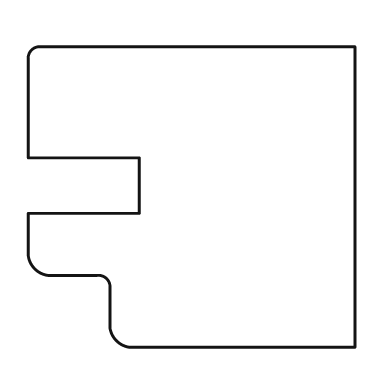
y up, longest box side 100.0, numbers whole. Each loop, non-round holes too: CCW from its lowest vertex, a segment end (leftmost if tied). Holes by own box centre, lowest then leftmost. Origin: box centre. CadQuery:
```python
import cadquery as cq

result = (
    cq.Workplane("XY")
    .moveTo(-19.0, -46.0)
    .lineTo(50.0, -46.0)
    .lineTo(50.0, 46.0)
    .lineTo(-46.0, 46.0)
    .threePointArc((-49.0, 45.0), (-50.0, 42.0))
    .lineTo(-50.0, 12.0)
    .lineTo(-16.0, 12.0)
    .lineTo(-16.0, -5.0)
    .lineTo(-50.0, -5.0)
    .lineTo(-50.0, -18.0)
    .threePointArc((-48.0, -22.0), (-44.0, -24.0))
    .lineTo(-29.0, -24.0)
    .threePointArc((-26.0, -25.0), (-25.0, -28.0))
    .lineTo(-25.0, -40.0)
    .threePointArc((-23.0, -44.0), (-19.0, -46.0))
    .close()
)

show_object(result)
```